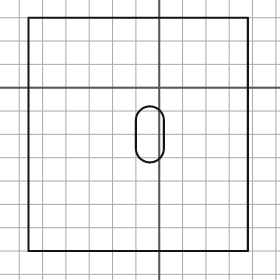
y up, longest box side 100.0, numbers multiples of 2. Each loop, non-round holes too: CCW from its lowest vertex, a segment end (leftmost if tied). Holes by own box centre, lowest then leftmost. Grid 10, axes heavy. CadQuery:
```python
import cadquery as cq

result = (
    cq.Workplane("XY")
    .moveTo(-56.0, -70.0)
    .lineTo(38.0, -70.0)
    .lineTo(38.0, 30.0)
    .lineTo(-56.0, 30.0)
    .close()
    .moveTo(-10.0, -26.0)
    .threePointArc((-4.0, -32.0), (2.0, -26.0))
    .lineTo(2.0, -14.0)
    .threePointArc((-4.0, -8.0), (-10.0, -14.0))
    .close()
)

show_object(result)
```